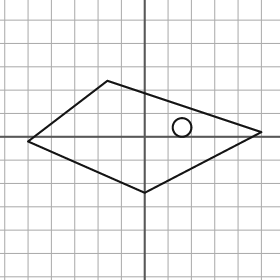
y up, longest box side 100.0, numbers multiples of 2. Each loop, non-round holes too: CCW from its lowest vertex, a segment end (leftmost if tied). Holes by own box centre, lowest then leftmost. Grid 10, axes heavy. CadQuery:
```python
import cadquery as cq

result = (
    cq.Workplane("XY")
    .moveTo(0.0, -24.0)
    .lineTo(50.0, 2.0)
    .lineTo(-16.0, 24.0)
    .lineTo(-50.0, -2.0)
    .close()
    .moveTo(16.0, 4.0)
    .circle(4.0)
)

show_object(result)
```